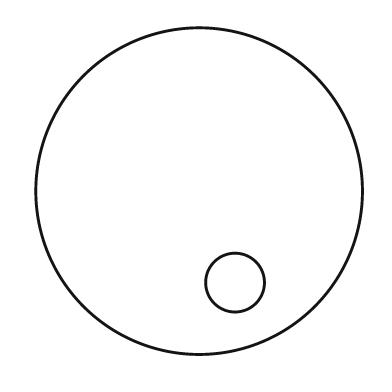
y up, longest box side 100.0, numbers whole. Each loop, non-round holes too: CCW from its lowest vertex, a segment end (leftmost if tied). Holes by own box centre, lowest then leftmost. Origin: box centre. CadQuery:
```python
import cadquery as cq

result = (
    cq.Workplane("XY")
    .moveTo(0.0, 0.0)
    .circle(50.0)
    .moveTo(11.0, -28.0)
    .circle(9.0)
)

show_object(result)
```